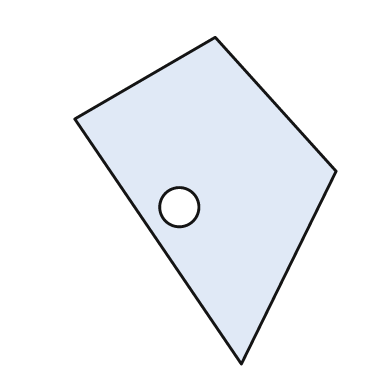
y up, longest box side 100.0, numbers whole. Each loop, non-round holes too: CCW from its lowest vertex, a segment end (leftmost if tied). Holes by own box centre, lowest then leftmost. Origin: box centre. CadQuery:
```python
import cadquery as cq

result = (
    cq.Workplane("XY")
    .moveTo(11.0, -50.0)
    .lineTo(40.0, 9.0)
    .lineTo(3.0, 50.0)
    .lineTo(-40.0, 25.0)
    .close()
    .moveTo(-8.0, -2.0)
    .circle(6.0)
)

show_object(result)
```